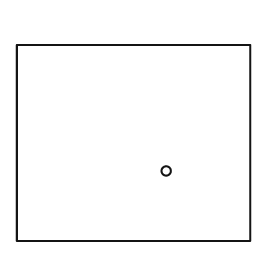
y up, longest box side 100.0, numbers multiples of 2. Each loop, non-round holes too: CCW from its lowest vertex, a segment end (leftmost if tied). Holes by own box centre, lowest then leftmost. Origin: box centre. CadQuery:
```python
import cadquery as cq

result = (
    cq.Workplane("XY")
    .moveTo(-50.0, -42.0)
    .lineTo(50.0, -42.0)
    .lineTo(50.0, 42.0)
    .lineTo(-50.0, 42.0)
    .close()
    .moveTo(14.0, -12.0)
    .circle(2.0)
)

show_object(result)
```